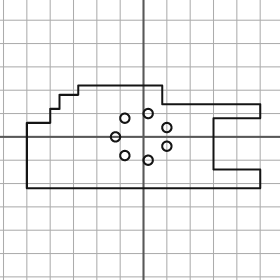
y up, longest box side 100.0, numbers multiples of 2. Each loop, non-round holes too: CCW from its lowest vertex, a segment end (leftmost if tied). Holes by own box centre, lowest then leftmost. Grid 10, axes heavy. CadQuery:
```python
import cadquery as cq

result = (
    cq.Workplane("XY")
    .moveTo(-50.0, -22.0)
    .lineTo(50.0, -22.0)
    .lineTo(50.0, -14.0)
    .lineTo(30.0, -14.0)
    .lineTo(30.0, 8.0)
    .lineTo(50.0, 8.0)
    .lineTo(50.0, 14.0)
    .lineTo(8.0, 14.0)
    .lineTo(8.0, 22.0)
    .lineTo(-28.0, 22.0)
    .lineTo(-28.0, 18.0)
    .lineTo(-36.0, 18.0)
    .lineTo(-36.0, 12.0)
    .lineTo(-40.0, 12.0)
    .lineTo(-40.0, 6.0)
    .lineTo(-50.0, 6.0)
    .close()
    .moveTo(2.0, -10.0)
    .circle(2.0)
    .moveTo(-8.0, -8.0)
    .circle(2.0)
    .moveTo(10.0, -4.0)
    .circle(2.0)
    .moveTo(-12.0, 0.0)
    .circle(2.0)
    .moveTo(10.0, 4.0)
    .circle(2.0)
    .moveTo(-8.0, 8.0)
    .circle(2.0)
    .moveTo(2.0, 10.0)
    .circle(2.0)
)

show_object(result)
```